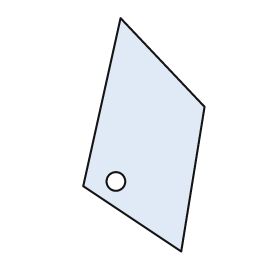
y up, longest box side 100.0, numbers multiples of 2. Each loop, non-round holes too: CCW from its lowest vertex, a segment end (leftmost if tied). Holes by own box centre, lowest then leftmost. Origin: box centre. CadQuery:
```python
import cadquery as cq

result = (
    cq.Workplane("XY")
    .moveTo(16.0, -50.0)
    .lineTo(26.0, 12.0)
    .lineTo(-10.0, 50.0)
    .lineTo(-26.0, -22.0)
    .close()
    .moveTo(-12.0, -20.0)
    .circle(4.0)
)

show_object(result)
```